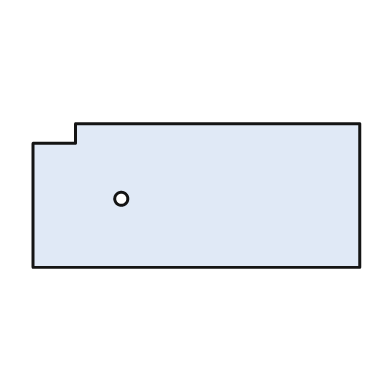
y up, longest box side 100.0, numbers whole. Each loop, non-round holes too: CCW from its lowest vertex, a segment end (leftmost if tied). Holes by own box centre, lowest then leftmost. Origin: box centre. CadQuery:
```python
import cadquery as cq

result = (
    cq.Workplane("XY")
    .moveTo(-50.0, -22.0)
    .lineTo(50.0, -22.0)
    .lineTo(50.0, 22.0)
    .lineTo(-37.0, 22.0)
    .lineTo(-37.0, 16.0)
    .lineTo(-50.0, 16.0)
    .close()
    .moveTo(-23.0, -1.0)
    .circle(2.0)
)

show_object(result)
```